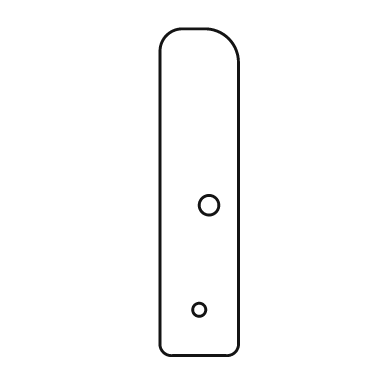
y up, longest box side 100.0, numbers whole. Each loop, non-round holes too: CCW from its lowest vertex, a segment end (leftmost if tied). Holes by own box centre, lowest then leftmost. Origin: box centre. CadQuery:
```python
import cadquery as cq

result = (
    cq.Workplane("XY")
    .moveTo(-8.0, -50.0)
    .lineTo(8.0, -50.0)
    .threePointArc((11.0, -49.0), (12.0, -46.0))
    .lineTo(12.0, 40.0)
    .threePointArc((9.0, 47.0), (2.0, 50.0))
    .lineTo(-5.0, 50.0)
    .threePointArc((-10.0, 48.0), (-12.0, 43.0))
    .lineTo(-12.0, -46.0)
    .threePointArc((-11.0, -49.0), (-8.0, -50.0))
    .close()
    .moveTo(0.0, -36.0)
    .circle(2.0)
    .moveTo(3.0, -4.0)
    .circle(3.0)
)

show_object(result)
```